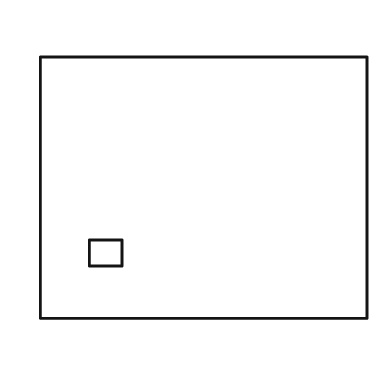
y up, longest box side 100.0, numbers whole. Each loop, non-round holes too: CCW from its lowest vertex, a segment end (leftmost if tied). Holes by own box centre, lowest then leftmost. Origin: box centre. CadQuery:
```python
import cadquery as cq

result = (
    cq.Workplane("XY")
    .moveTo(-50.0, -40.0)
    .lineTo(50.0, -40.0)
    .lineTo(50.0, 40.0)
    .lineTo(-50.0, 40.0)
    .close()
    .moveTo(-35.0, -24.0)
    .lineTo(-25.0, -24.0)
    .lineTo(-25.0, -16.0)
    .lineTo(-35.0, -16.0)
    .close()
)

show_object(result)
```